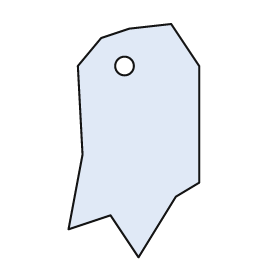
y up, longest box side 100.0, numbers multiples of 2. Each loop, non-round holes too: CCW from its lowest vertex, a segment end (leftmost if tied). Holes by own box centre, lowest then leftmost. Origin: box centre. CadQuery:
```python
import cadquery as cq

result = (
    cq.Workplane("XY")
    .moveTo(2.0, -50.0)
    .lineTo(18.0, -24.0)
    .lineTo(28.0, -18.0)
    .lineTo(28.0, 32.0)
    .lineTo(16.0, 50.0)
    .lineTo(-2.0, 48.0)
    .lineTo(-14.0, 44.0)
    .lineTo(-24.0, 32.0)
    .lineTo(-22.0, -6.0)
    .lineTo(-28.0, -38.0)
    .lineTo(-10.0, -32.0)
    .close()
    .moveTo(-4.0, 32.0)
    .circle(4.0)
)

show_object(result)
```